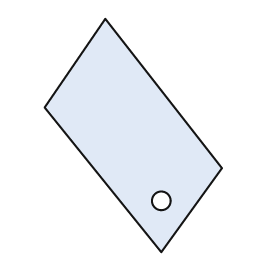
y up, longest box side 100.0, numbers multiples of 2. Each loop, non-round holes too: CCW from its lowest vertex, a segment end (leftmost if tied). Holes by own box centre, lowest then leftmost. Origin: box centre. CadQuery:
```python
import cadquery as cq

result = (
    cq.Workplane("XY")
    .moveTo(12.0, -50.0)
    .lineTo(38.0, -14.0)
    .lineTo(-12.0, 50.0)
    .lineTo(-38.0, 12.0)
    .close()
    .moveTo(12.0, -28.0)
    .circle(4.0)
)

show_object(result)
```